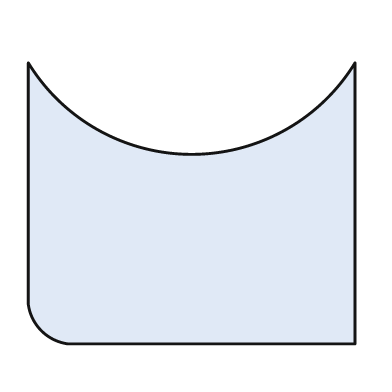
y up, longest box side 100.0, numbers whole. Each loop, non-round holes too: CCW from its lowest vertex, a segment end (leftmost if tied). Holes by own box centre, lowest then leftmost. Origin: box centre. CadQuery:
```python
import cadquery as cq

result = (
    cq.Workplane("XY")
    .moveTo(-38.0, -43.0)
    .lineTo(50.0, -43.0)
    .lineTo(50.0, 43.0)
    .threePointArc((0.0, 15.0), (-50.0, 43.0))
    .lineTo(-50.0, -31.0)
    .threePointArc((-46.0, -39.0), (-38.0, -43.0))
    .close()
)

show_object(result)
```